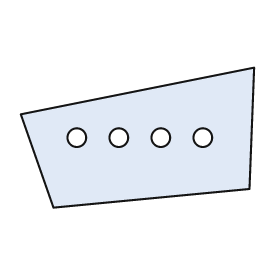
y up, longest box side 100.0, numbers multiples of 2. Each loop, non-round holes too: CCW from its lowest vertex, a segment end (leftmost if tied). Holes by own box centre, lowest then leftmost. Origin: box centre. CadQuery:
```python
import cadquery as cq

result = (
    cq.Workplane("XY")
    .moveTo(-36.0, -30.0)
    .lineTo(48.0, -22.0)
    .lineTo(50.0, 30.0)
    .lineTo(-50.0, 10.0)
    .close()
    .moveTo(-26.0, 0.0)
    .circle(4.0)
    .moveTo(-8.0, 0.0)
    .circle(4.0)
    .moveTo(10.0, 0.0)
    .circle(4.0)
    .moveTo(28.0, 0.0)
    .circle(4.0)
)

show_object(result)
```